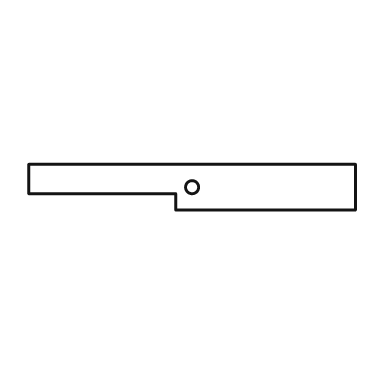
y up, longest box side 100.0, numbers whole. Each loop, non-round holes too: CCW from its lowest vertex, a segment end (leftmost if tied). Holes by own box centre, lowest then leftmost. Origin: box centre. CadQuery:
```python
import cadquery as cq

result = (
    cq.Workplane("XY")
    .moveTo(-5.0, -7.0)
    .lineTo(50.0, -7.0)
    .lineTo(50.0, 7.0)
    .lineTo(-50.0, 7.0)
    .lineTo(-50.0, -2.0)
    .lineTo(-5.0, -2.0)
    .close()
    .moveTo(0.0, 0.0)
    .circle(2.0)
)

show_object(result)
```